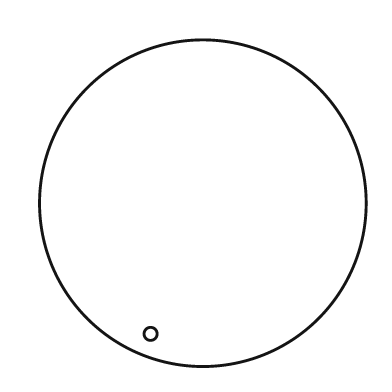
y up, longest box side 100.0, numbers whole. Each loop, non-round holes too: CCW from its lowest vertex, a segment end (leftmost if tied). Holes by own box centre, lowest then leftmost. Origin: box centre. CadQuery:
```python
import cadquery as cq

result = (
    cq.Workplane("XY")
    .moveTo(0.0, 0.0)
    .circle(50.0)
    .moveTo(-16.0, -40.0)
    .circle(2.0)
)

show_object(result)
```